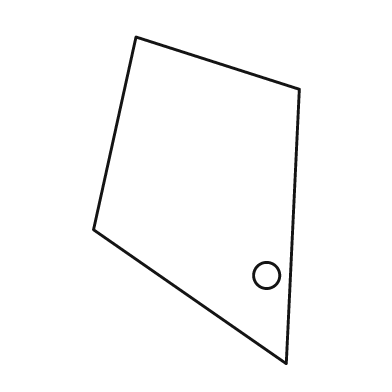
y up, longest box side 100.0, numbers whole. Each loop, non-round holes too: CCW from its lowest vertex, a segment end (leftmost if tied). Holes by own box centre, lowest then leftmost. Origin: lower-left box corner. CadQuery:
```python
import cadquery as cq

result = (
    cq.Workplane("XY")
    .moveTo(59.0, 0.0)
    .lineTo(63.0, 84.0)
    .lineTo(13.0, 100.0)
    .lineTo(0.0, 41.0)
    .close()
    .moveTo(53.0, 27.0)
    .circle(4.0)
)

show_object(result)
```